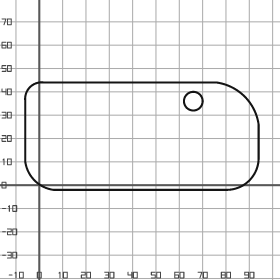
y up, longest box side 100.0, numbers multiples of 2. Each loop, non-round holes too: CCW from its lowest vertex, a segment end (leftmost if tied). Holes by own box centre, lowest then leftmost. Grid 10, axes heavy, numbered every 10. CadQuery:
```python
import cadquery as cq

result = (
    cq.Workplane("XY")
    .moveTo(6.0, -2.0)
    .lineTo(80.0, -2.0)
    .threePointArc((90.0, 2.0), (94.0, 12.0))
    .lineTo(94.0, 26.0)
    .threePointArc((88.0, 38.0), (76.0, 44.0))
    .lineTo(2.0, 44.0)
    .threePointArc((-4.0, 42.0), (-6.0, 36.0))
    .lineTo(-6.0, 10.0)
    .threePointArc((-2.0, 2.0), (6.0, -2.0))
    .close()
    .moveTo(66.0, 36.0)
    .circle(4.0)
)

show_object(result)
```